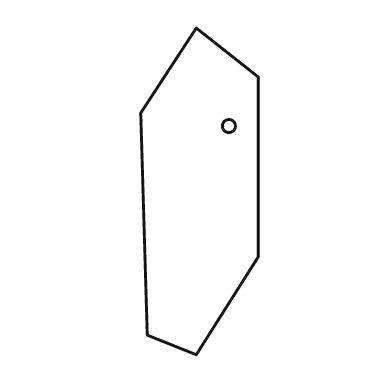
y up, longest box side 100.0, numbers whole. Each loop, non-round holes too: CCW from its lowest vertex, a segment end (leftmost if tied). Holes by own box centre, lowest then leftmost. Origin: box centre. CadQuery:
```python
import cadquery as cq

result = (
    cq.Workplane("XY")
    .moveTo(-1.0, -50.0)
    .lineTo(18.0, -20.0)
    .lineTo(18.0, 35.0)
    .lineTo(-1.0, 50.0)
    .lineTo(-18.0, 24.0)
    .lineTo(-16.0, -44.0)
    .close()
    .moveTo(9.0, 20.0)
    .circle(2.0)
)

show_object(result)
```